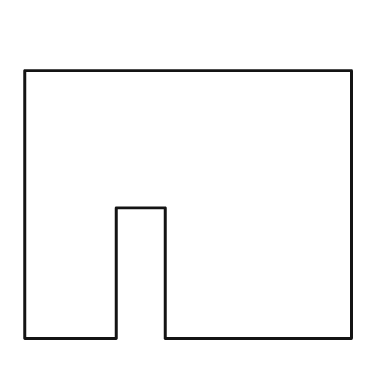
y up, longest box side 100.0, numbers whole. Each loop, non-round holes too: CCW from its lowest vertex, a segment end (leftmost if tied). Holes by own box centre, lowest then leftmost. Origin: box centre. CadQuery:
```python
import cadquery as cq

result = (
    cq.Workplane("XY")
    .moveTo(-50.0, -41.0)
    .lineTo(-22.0, -41.0)
    .lineTo(-22.0, -1.0)
    .lineTo(-7.0, -1.0)
    .lineTo(-7.0, -41.0)
    .lineTo(50.0, -41.0)
    .lineTo(50.0, 41.0)
    .lineTo(-50.0, 41.0)
    .close()
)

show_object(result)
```